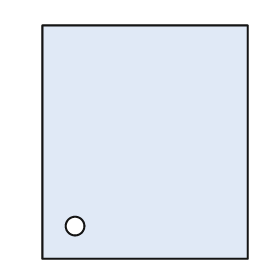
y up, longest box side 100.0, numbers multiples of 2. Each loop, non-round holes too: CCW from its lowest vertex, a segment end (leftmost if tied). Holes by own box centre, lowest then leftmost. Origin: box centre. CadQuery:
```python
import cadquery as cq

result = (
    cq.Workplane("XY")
    .moveTo(-44.0, -50.0)
    .lineTo(44.0, -50.0)
    .lineTo(44.0, 50.0)
    .lineTo(-44.0, 50.0)
    .close()
    .moveTo(-30.0, -36.0)
    .circle(4.0)
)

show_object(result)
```